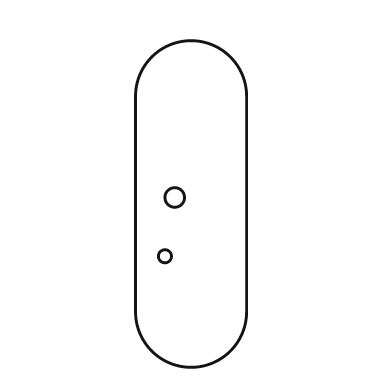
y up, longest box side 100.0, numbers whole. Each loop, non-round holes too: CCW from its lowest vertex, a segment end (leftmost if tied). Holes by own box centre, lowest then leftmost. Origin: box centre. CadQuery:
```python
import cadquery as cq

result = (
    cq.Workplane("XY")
    .moveTo(-17.0, -33.0)
    .threePointArc((0.0, -50.0), (17.0, -33.0))
    .lineTo(17.0, 33.0)
    .threePointArc((0.0, 50.0), (-17.0, 33.0))
    .close()
    .moveTo(-8.0, -16.0)
    .circle(2.0)
    .moveTo(-5.0, 2.0)
    .circle(3.0)
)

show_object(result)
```